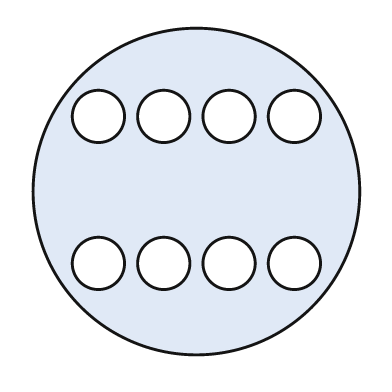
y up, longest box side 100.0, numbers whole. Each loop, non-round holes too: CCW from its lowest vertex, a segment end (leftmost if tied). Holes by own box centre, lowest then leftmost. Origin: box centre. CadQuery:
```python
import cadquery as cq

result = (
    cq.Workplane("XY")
    .moveTo(0.0, 0.0)
    .circle(50.0)
    .moveTo(-30.0, -22.0)
    .circle(8.0)
    .moveTo(-10.0, -22.0)
    .circle(8.0)
    .moveTo(10.0, -22.0)
    .circle(8.0)
    .moveTo(30.0, -22.0)
    .circle(8.0)
    .moveTo(-30.0, 23.0)
    .circle(8.0)
    .moveTo(-10.0, 23.0)
    .circle(8.0)
    .moveTo(10.0, 23.0)
    .circle(8.0)
    .moveTo(30.0, 23.0)
    .circle(8.0)
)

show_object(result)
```